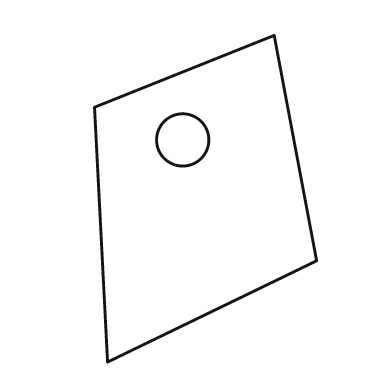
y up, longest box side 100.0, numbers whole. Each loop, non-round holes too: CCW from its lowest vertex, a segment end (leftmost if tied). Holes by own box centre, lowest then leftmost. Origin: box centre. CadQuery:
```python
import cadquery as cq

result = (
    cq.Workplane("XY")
    .moveTo(-30.0, -50.0)
    .lineTo(34.0, -19.0)
    .lineTo(21.0, 50.0)
    .lineTo(-34.0, 28.0)
    .close()
    .moveTo(-7.0, 18.0)
    .circle(8.0)
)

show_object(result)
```